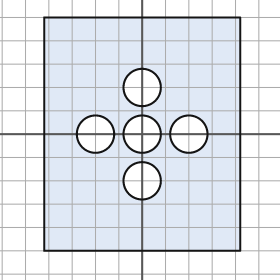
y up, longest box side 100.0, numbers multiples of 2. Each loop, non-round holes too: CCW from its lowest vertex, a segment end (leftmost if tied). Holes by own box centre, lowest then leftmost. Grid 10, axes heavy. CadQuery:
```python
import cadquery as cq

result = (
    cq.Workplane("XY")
    .moveTo(-42.0, -50.0)
    .lineTo(42.0, -50.0)
    .lineTo(42.0, 50.0)
    .lineTo(-42.0, 50.0)
    .close()
    .moveTo(0.0, -20.0)
    .circle(8.0)
    .moveTo(-20.0, 0.0)
    .circle(8.0)
    .moveTo(0.0, 0.0)
    .circle(8.0)
    .moveTo(20.0, 0.0)
    .circle(8.0)
    .moveTo(0.0, 20.0)
    .circle(8.0)
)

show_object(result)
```